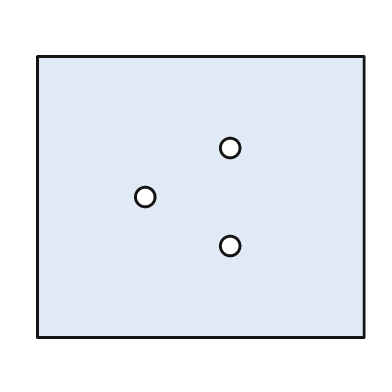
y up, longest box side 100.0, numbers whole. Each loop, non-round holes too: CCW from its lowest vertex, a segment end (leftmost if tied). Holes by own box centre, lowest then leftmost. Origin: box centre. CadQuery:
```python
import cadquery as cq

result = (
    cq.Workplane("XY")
    .moveTo(-50.0, -43.0)
    .lineTo(50.0, -43.0)
    .lineTo(50.0, 43.0)
    .lineTo(-50.0, 43.0)
    .close()
    .moveTo(9.0, -15.0)
    .circle(3.0)
    .moveTo(-17.0, 0.0)
    .circle(3.0)
    .moveTo(9.0, 15.0)
    .circle(3.0)
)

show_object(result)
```